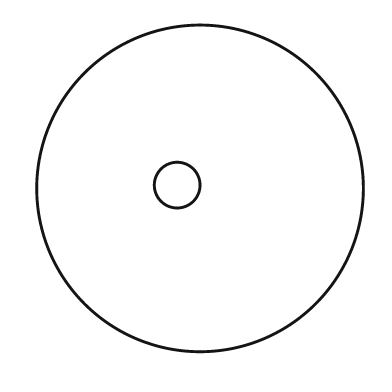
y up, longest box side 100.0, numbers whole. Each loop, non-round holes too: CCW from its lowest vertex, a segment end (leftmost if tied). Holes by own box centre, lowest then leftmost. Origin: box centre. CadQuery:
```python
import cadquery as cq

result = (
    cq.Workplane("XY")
    .moveTo(0.0, 0.0)
    .circle(50.0)
    .moveTo(-7.0, 1.0)
    .circle(7.0)
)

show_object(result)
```